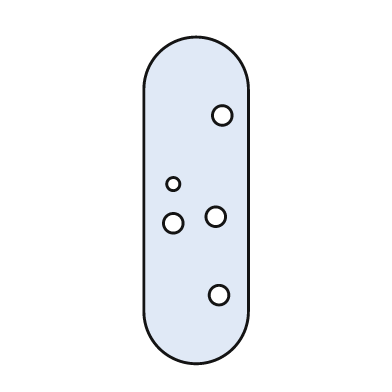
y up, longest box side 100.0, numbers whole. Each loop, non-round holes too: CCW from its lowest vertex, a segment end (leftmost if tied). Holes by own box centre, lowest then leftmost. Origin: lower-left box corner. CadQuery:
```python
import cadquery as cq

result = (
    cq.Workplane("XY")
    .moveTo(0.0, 16.0)
    .threePointArc((16.0, 0.0), (32.0, 16.0))
    .lineTo(32.0, 84.0)
    .threePointArc((16.0, 100.0), (0.0, 84.0))
    .close()
    .moveTo(23.0, 21.0)
    .circle(3.0)
    .moveTo(9.0, 43.0)
    .circle(3.0)
    .moveTo(22.0, 45.0)
    .circle(3.0)
    .moveTo(9.0, 55.0)
    .circle(2.0)
    .moveTo(24.0, 76.0)
    .circle(3.0)
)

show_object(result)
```